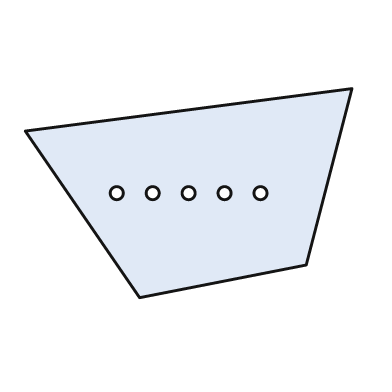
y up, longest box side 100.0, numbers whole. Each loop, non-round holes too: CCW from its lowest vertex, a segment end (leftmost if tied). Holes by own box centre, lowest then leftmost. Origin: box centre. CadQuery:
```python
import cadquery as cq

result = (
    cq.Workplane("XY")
    .moveTo(-15.0, -32.0)
    .lineTo(36.0, -22.0)
    .lineTo(50.0, 32.0)
    .lineTo(-50.0, 19.0)
    .close()
    .moveTo(-22.0, 0.0)
    .circle(2.0)
    .moveTo(-11.0, 0.0)
    .circle(2.0)
    .moveTo(0.0, 0.0)
    .circle(2.0)
    .moveTo(11.0, 0.0)
    .circle(2.0)
    .moveTo(22.0, 0.0)
    .circle(2.0)
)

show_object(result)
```